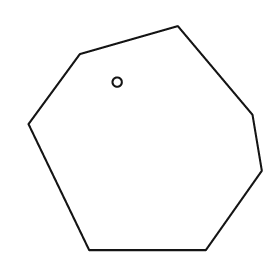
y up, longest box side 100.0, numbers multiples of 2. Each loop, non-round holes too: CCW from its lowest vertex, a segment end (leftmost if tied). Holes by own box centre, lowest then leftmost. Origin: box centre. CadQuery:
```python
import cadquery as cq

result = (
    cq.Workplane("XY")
    .moveTo(-24.0, -48.0)
    .lineTo(26.0, -48.0)
    .lineTo(50.0, -14.0)
    .lineTo(46.0, 10.0)
    .lineTo(14.0, 48.0)
    .lineTo(-28.0, 36.0)
    .lineTo(-50.0, 6.0)
    .close()
    .moveTo(-12.0, 24.0)
    .circle(2.0)
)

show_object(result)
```